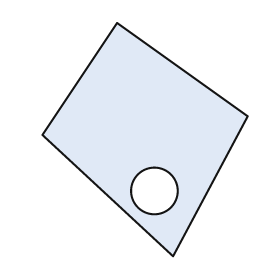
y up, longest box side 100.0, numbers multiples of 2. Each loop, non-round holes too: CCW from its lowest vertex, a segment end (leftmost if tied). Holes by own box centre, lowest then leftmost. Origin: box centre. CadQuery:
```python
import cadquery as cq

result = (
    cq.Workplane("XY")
    .moveTo(12.0, -50.0)
    .lineTo(44.0, 10.0)
    .lineTo(-12.0, 50.0)
    .lineTo(-44.0, 2.0)
    .close()
    .moveTo(4.0, -22.0)
    .circle(10.0)
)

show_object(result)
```